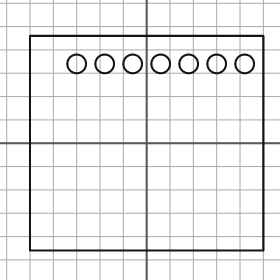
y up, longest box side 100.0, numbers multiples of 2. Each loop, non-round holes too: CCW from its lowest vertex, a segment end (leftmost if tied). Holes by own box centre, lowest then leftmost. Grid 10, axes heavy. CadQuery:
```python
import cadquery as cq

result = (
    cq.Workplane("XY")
    .moveTo(-50.0, -46.0)
    .lineTo(50.0, -46.0)
    .lineTo(50.0, 46.0)
    .lineTo(-50.0, 46.0)
    .close()
    .moveTo(-30.0, 34.0)
    .circle(4.0)
    .moveTo(-18.0, 34.0)
    .circle(4.0)
    .moveTo(-6.0, 34.0)
    .circle(4.0)
    .moveTo(6.0, 34.0)
    .circle(4.0)
    .moveTo(18.0, 34.0)
    .circle(4.0)
    .moveTo(30.0, 34.0)
    .circle(4.0)
    .moveTo(42.0, 34.0)
    .circle(4.0)
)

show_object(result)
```